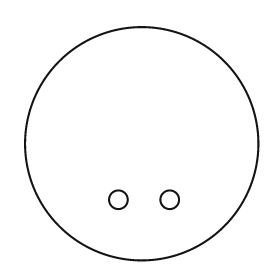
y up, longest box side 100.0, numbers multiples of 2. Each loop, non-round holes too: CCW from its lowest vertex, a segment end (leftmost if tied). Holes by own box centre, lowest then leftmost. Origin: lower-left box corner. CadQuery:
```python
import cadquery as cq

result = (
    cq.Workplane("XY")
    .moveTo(50.0, 50.0)
    .circle(50.0)
    .moveTo(40.0, 26.0)
    .circle(4.0)
    .moveTo(62.0, 26.0)
    .circle(4.0)
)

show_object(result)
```